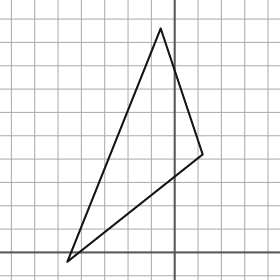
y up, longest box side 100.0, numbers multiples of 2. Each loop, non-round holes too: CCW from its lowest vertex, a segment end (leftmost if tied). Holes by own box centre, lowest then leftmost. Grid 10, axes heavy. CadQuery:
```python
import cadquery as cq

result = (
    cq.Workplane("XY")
    .moveTo(-46.0, -4.0)
    .lineTo(12.0, 42.0)
    .lineTo(-6.0, 96.0)
    .close()
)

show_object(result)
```